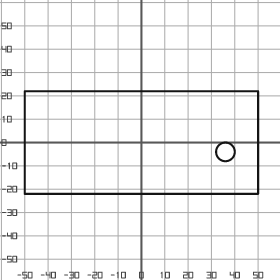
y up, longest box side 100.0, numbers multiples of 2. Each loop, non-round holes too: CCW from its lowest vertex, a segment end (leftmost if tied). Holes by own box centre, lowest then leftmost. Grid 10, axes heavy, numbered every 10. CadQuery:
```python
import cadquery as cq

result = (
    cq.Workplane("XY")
    .moveTo(-50.0, -22.0)
    .lineTo(50.0, -22.0)
    .lineTo(50.0, 22.0)
    .lineTo(-50.0, 22.0)
    .close()
    .moveTo(36.0, -4.0)
    .circle(4.0)
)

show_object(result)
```